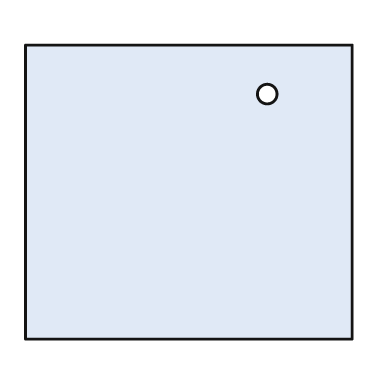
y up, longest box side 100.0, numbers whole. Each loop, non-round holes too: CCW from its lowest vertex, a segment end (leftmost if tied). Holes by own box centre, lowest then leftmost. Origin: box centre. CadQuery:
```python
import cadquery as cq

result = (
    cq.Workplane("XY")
    .moveTo(-50.0, -45.0)
    .lineTo(50.0, -45.0)
    .lineTo(50.0, 45.0)
    .lineTo(-50.0, 45.0)
    .close()
    .moveTo(24.0, 30.0)
    .circle(3.0)
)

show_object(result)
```